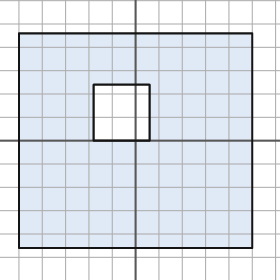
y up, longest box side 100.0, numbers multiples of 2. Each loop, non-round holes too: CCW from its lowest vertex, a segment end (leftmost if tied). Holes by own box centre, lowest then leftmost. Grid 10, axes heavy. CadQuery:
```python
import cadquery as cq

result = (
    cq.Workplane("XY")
    .moveTo(-50.0, -46.0)
    .lineTo(50.0, -46.0)
    .lineTo(50.0, 46.0)
    .lineTo(-50.0, 46.0)
    .close()
    .moveTo(-18.0, 0.0)
    .lineTo(6.0, 0.0)
    .lineTo(6.0, 24.0)
    .lineTo(-18.0, 24.0)
    .close()
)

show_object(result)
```